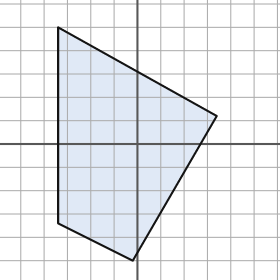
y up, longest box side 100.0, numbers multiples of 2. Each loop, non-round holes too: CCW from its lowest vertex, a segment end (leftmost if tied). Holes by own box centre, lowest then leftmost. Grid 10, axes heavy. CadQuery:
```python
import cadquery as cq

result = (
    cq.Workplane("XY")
    .moveTo(-2.0, -50.0)
    .lineTo(34.0, 12.0)
    .lineTo(-34.0, 50.0)
    .lineTo(-34.0, -34.0)
    .close()
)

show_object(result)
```